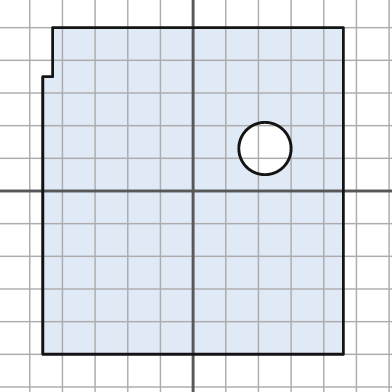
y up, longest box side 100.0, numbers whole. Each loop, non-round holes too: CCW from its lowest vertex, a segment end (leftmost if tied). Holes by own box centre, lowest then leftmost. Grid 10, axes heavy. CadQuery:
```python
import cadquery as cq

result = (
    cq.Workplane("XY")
    .moveTo(-46.0, -50.0)
    .lineTo(46.0, -50.0)
    .lineTo(46.0, 50.0)
    .lineTo(-43.0, 50.0)
    .lineTo(-43.0, 35.0)
    .lineTo(-46.0, 35.0)
    .close()
    .moveTo(22.0, 13.0)
    .circle(8.0)
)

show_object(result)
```